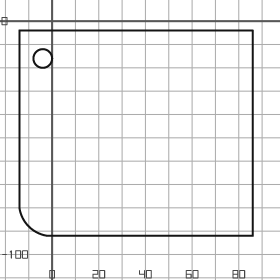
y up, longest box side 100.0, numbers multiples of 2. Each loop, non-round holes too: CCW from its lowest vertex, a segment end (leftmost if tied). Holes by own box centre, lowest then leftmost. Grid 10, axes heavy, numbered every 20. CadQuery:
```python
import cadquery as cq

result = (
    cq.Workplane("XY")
    .moveTo(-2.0, -92.0)
    .lineTo(86.0, -92.0)
    .lineTo(86.0, -4.0)
    .lineTo(-14.0, -4.0)
    .lineTo(-14.0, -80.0)
    .threePointArc((-10.0, -88.0), (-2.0, -92.0))
    .close()
    .moveTo(-4.0, -16.0)
    .circle(4.0)
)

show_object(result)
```